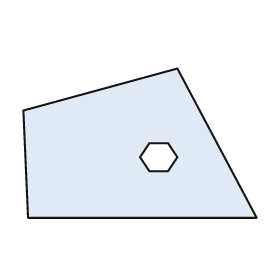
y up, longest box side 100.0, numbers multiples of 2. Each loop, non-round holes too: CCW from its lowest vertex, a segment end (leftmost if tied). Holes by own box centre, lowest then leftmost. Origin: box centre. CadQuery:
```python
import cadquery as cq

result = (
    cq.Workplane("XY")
    .moveTo(-48.0, -32.0)
    .lineTo(50.0, -32.0)
    .lineTo(16.0, 32.0)
    .lineTo(-50.0, 14.0)
    .close()
    .moveTo(4.0, -12.0)
    .lineTo(12.0, -12.0)
    .lineTo(16.0, -6.0)
    .lineTo(12.0, 0.0)
    .lineTo(4.0, 0.0)
    .lineTo(0.0, -6.0)
    .close()
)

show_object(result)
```